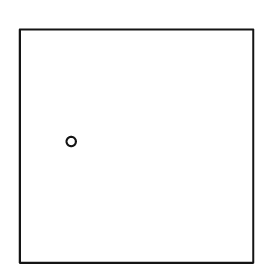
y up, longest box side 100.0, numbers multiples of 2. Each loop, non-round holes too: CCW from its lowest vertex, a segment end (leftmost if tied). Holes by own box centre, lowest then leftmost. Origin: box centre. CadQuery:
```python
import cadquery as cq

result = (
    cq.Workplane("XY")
    .moveTo(-50.0, -50.0)
    .lineTo(50.0, -50.0)
    .lineTo(50.0, 50.0)
    .lineTo(-50.0, 50.0)
    .close()
    .moveTo(-28.0, 2.0)
    .circle(2.0)
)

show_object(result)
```